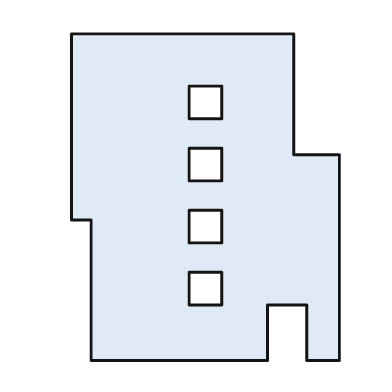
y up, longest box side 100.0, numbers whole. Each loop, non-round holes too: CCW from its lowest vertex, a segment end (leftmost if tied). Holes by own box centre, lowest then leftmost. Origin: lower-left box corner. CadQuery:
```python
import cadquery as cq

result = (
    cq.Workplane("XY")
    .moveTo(6.0, 0.0)
    .lineTo(60.0, 0.0)
    .lineTo(60.0, 17.0)
    .lineTo(72.0, 17.0)
    .lineTo(72.0, 0.0)
    .lineTo(82.0, 0.0)
    .lineTo(82.0, 63.0)
    .lineTo(68.0, 63.0)
    .lineTo(68.0, 100.0)
    .lineTo(0.0, 100.0)
    .lineTo(0.0, 43.0)
    .lineTo(6.0, 43.0)
    .close()
    .moveTo(36.0, 17.0)
    .lineTo(46.0, 17.0)
    .lineTo(46.0, 27.0)
    .lineTo(36.0, 27.0)
    .close()
    .moveTo(36.0, 36.0)
    .lineTo(46.0, 36.0)
    .lineTo(46.0, 46.0)
    .lineTo(36.0, 46.0)
    .close()
    .moveTo(36.0, 55.0)
    .lineTo(46.0, 55.0)
    .lineTo(46.0, 65.0)
    .lineTo(36.0, 65.0)
    .close()
    .moveTo(36.0, 74.0)
    .lineTo(46.0, 74.0)
    .lineTo(46.0, 84.0)
    .lineTo(36.0, 84.0)
    .close()
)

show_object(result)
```